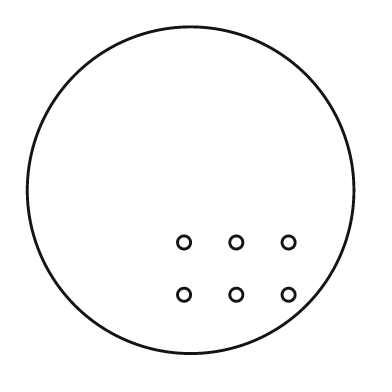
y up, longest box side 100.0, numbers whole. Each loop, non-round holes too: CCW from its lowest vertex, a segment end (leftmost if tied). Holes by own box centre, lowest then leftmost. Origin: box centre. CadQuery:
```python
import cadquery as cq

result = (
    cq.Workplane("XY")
    .moveTo(0.0, 0.0)
    .circle(50.0)
    .moveTo(-2.0, -32.0)
    .circle(2.0)
    .moveTo(14.0, -32.0)
    .circle(2.0)
    .moveTo(30.0, -32.0)
    .circle(2.0)
    .moveTo(-2.0, -16.0)
    .circle(2.0)
    .moveTo(14.0, -16.0)
    .circle(2.0)
    .moveTo(30.0, -16.0)
    .circle(2.0)
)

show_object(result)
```